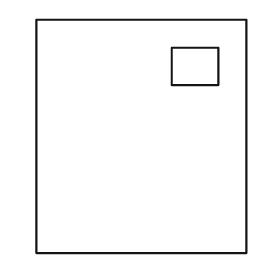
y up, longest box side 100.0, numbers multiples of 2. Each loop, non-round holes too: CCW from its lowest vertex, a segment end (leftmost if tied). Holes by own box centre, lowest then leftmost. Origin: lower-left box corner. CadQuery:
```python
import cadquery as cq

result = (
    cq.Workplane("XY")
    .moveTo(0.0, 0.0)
    .lineTo(90.0, 0.0)
    .lineTo(90.0, 100.0)
    .lineTo(0.0, 100.0)
    .close()
    .moveTo(58.0, 72.0)
    .lineTo(78.0, 72.0)
    .lineTo(78.0, 88.0)
    .lineTo(58.0, 88.0)
    .close()
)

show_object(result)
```